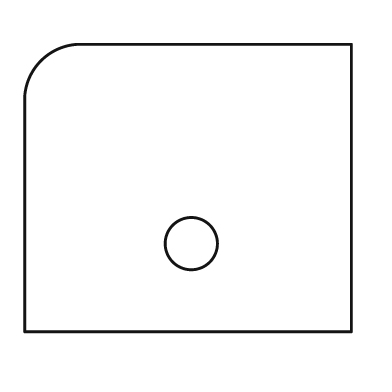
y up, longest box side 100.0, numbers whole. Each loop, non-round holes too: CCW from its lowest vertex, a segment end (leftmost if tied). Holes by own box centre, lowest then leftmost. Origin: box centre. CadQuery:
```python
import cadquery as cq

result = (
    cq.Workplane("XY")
    .moveTo(-50.0, -44.0)
    .lineTo(50.0, -44.0)
    .lineTo(50.0, 44.0)
    .lineTo(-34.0, 44.0)
    .threePointArc((-45.0, 39.0), (-50.0, 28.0))
    .close()
    .moveTo(1.0, -17.0)
    .circle(8.0)
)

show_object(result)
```